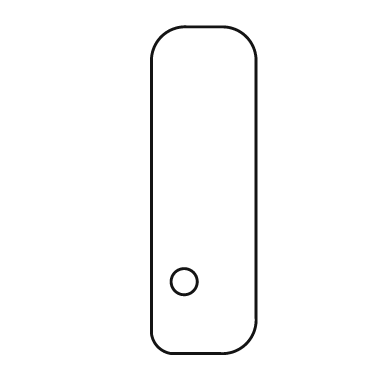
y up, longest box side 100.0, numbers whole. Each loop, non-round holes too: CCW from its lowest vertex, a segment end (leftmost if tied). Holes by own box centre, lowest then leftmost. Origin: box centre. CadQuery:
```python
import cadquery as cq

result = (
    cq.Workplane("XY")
    .moveTo(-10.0, -50.0)
    .lineTo(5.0, -50.0)
    .threePointArc((13.0, -47.0), (16.0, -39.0))
    .lineTo(16.0, 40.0)
    .threePointArc((13.0, 47.0), (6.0, 50.0))
    .lineTo(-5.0, 50.0)
    .threePointArc((-13.0, 47.0), (-16.0, 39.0))
    .lineTo(-16.0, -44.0)
    .threePointArc((-14.0, -48.0), (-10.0, -50.0))
    .close()
    .moveTo(-6.0, -28.0)
    .circle(4.0)
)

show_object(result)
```